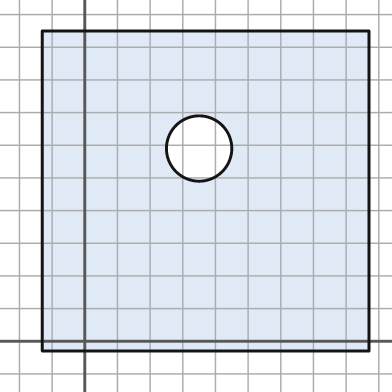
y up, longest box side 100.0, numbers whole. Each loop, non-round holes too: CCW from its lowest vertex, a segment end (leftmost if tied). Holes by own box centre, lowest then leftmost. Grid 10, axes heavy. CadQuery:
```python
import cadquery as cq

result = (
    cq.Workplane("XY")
    .moveTo(-13.0, -3.0)
    .lineTo(87.0, -3.0)
    .lineTo(87.0, 95.0)
    .lineTo(-13.0, 95.0)
    .close()
    .moveTo(35.0, 59.0)
    .circle(10.0)
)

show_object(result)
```